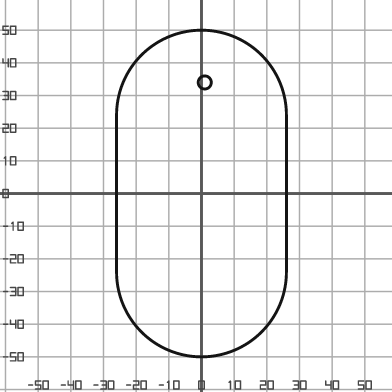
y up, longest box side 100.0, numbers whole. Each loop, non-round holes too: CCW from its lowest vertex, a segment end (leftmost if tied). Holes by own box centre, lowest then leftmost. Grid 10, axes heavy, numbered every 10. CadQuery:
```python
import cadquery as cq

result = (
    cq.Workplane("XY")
    .moveTo(-26.0, -24.0)
    .threePointArc((0.0, -50.0), (26.0, -24.0))
    .lineTo(26.0, 24.0)
    .threePointArc((0.0, 50.0), (-26.0, 24.0))
    .close()
    .moveTo(1.0, 34.0)
    .circle(2.0)
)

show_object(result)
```